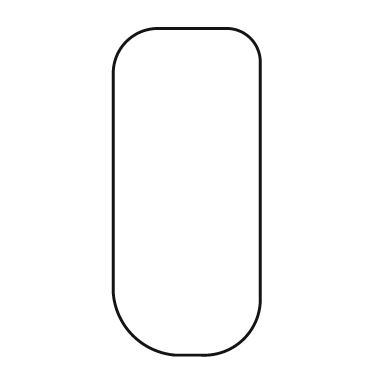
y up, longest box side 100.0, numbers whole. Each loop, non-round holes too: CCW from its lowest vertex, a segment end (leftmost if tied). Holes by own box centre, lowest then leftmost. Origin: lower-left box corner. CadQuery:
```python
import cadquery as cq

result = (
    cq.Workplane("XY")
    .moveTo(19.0, 0.0)
    .lineTo(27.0, 0.0)
    .threePointArc((40.0, 5.0), (45.0, 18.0))
    .lineTo(45.0, 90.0)
    .threePointArc((42.0, 97.0), (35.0, 100.0))
    .lineTo(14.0, 100.0)
    .threePointArc((4.0, 96.0), (0.0, 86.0))
    .lineTo(0.0, 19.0)
    .threePointArc((6.0, 6.0), (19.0, 0.0))
    .close()
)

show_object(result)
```